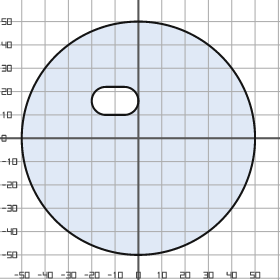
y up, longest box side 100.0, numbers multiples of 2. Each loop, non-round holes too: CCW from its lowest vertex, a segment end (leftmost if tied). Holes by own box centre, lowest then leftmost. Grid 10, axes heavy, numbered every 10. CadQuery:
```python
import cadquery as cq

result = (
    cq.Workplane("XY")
    .moveTo(0.0, 0.0)
    .circle(50.0)
    .moveTo(-14.0, 10.0)
    .lineTo(-6.0, 10.0)
    .threePointArc((0.0, 16.0), (-6.0, 22.0))
    .lineTo(-14.0, 22.0)
    .threePointArc((-20.0, 16.0), (-14.0, 10.0))
    .close()
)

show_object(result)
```